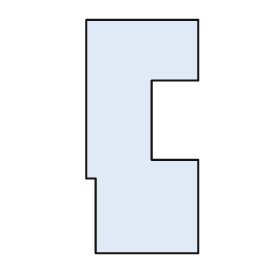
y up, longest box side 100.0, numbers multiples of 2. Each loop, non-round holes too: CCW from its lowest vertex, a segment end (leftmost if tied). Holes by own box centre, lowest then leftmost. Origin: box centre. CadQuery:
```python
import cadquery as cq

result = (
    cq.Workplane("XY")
    .moveTo(-20.0, -50.0)
    .lineTo(24.0, -50.0)
    .lineTo(24.0, -10.0)
    .lineTo(4.0, -10.0)
    .lineTo(4.0, 24.0)
    .lineTo(24.0, 24.0)
    .lineTo(24.0, 50.0)
    .lineTo(-24.0, 50.0)
    .lineTo(-24.0, -18.0)
    .lineTo(-20.0, -18.0)
    .close()
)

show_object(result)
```